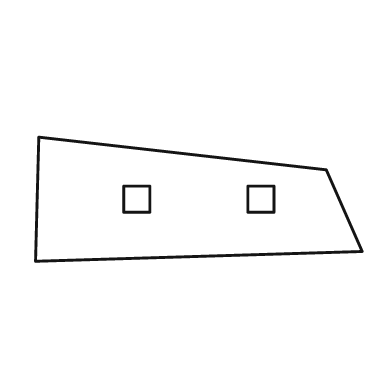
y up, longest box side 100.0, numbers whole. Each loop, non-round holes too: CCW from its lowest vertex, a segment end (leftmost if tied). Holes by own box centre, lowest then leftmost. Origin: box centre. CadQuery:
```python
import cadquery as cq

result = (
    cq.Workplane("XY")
    .moveTo(-50.0, -19.0)
    .lineTo(50.0, -16.0)
    .lineTo(39.0, 9.0)
    .lineTo(-49.0, 19.0)
    .close()
    .moveTo(-23.0, -4.0)
    .lineTo(-15.0, -4.0)
    .lineTo(-15.0, 4.0)
    .lineTo(-23.0, 4.0)
    .close()
    .moveTo(15.0, -4.0)
    .lineTo(23.0, -4.0)
    .lineTo(23.0, 4.0)
    .lineTo(15.0, 4.0)
    .close()
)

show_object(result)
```